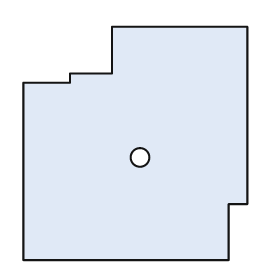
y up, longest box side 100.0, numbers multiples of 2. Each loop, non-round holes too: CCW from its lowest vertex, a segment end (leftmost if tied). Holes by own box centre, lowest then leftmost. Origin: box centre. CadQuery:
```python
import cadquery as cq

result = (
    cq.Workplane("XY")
    .moveTo(-48.0, -50.0)
    .lineTo(40.0, -50.0)
    .lineTo(40.0, -26.0)
    .lineTo(48.0, -26.0)
    .lineTo(48.0, 50.0)
    .lineTo(-10.0, 50.0)
    .lineTo(-10.0, 30.0)
    .lineTo(-28.0, 30.0)
    .lineTo(-28.0, 26.0)
    .lineTo(-48.0, 26.0)
    .close()
    .moveTo(2.0, -6.0)
    .circle(4.0)
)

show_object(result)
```